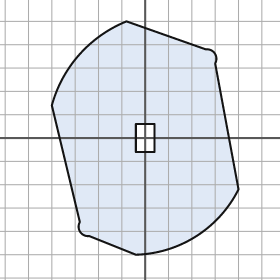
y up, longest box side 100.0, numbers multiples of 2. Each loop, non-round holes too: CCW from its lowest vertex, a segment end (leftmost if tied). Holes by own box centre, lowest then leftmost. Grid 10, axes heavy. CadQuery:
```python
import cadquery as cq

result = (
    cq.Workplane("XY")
    .moveTo(-4.0, -50.0)
    .threePointArc((22.0, -42.0), (40.0, -22.0))
    .lineTo(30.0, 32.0)
    .threePointArc((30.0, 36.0), (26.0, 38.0))
    .lineTo(-8.0, 50.0)
    .threePointArc((-28.0, 36.0), (-40.0, 14.0))
    .lineTo(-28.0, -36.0)
    .threePointArc((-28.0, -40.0), (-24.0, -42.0))
    .close()
    .moveTo(-4.0, -6.0)
    .lineTo(4.0, -6.0)
    .lineTo(4.0, 6.0)
    .lineTo(-4.0, 6.0)
    .close()
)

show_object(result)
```